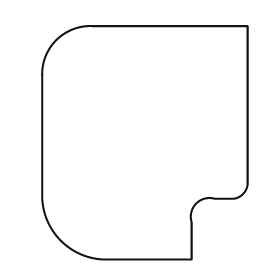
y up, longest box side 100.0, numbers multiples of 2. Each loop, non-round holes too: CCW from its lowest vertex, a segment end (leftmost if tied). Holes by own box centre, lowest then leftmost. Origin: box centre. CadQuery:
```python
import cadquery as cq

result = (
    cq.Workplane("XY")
    .moveTo(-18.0, -50.0)
    .lineTo(20.0, -50.0)
    .lineTo(20.0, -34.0)
    .threePointArc((22.0, -26.0), (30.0, -24.0))
    .lineTo(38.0, -24.0)
    .threePointArc((42.0, -22.0), (44.0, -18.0))
    .lineTo(44.0, 50.0)
    .lineTo(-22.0, 50.0)
    .threePointArc((-38.0, 44.0), (-44.0, 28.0))
    .lineTo(-44.0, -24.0)
    .threePointArc((-36.0, -42.0), (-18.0, -50.0))
    .close()
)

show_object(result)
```